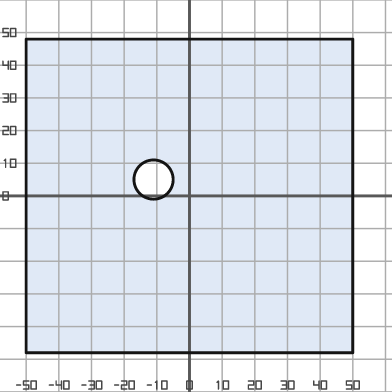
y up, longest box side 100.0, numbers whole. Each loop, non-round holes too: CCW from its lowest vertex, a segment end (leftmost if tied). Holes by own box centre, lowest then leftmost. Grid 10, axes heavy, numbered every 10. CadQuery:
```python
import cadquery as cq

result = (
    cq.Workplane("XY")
    .moveTo(-50.0, -48.0)
    .lineTo(50.0, -48.0)
    .lineTo(50.0, 48.0)
    .lineTo(-50.0, 48.0)
    .close()
    .moveTo(-11.0, 5.0)
    .circle(6.0)
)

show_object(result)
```